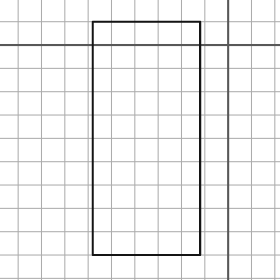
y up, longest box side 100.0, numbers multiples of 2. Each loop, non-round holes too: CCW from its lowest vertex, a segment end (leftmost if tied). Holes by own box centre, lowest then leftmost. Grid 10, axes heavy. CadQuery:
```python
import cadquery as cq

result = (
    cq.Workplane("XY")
    .moveTo(-58.0, -90.0)
    .lineTo(-12.0, -90.0)
    .lineTo(-12.0, 10.0)
    .lineTo(-58.0, 10.0)
    .close()
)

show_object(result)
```